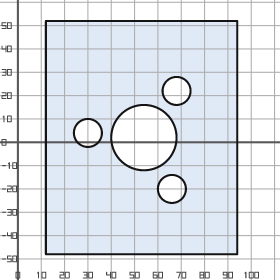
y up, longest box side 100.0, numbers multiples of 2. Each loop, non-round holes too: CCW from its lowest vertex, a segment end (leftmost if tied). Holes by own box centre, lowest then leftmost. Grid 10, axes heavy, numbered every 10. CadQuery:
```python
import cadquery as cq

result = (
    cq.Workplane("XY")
    .moveTo(12.0, -48.0)
    .lineTo(94.0, -48.0)
    .lineTo(94.0, 52.0)
    .lineTo(12.0, 52.0)
    .close()
    .moveTo(66.0, -20.0)
    .circle(6.0)
    .moveTo(54.0, 2.0)
    .circle(14.0)
    .moveTo(30.0, 4.0)
    .circle(6.0)
    .moveTo(68.0, 22.0)
    .circle(6.0)
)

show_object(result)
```